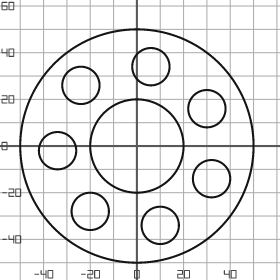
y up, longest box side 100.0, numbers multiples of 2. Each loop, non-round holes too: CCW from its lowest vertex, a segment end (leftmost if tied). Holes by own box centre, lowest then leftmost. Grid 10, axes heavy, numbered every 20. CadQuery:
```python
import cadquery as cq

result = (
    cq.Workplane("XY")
    .moveTo(0.0, 0.0)
    .circle(50.0)
    .moveTo(10.0, -34.0)
    .circle(8.0)
    .moveTo(-20.0, -28.0)
    .circle(8.0)
    .moveTo(32.0, -14.0)
    .circle(8.0)
    .moveTo(-34.0, -2.0)
    .circle(8.0)
    .moveTo(0.0, 0.0)
    .circle(20.0)
    .moveTo(30.0, 16.0)
    .circle(8.0)
    .moveTo(-24.0, 26.0)
    .circle(8.0)
    .moveTo(6.0, 34.0)
    .circle(8.0)
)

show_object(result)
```